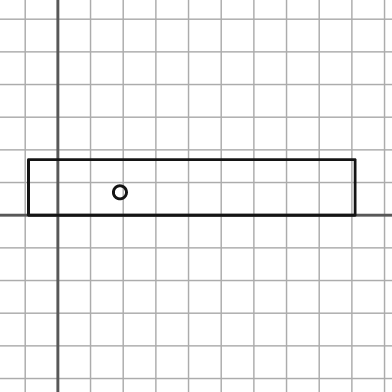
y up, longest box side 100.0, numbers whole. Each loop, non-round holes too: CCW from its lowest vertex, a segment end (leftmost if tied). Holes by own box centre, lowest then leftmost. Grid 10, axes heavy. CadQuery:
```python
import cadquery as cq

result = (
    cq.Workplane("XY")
    .moveTo(-9.0, 0.0)
    .lineTo(91.0, 0.0)
    .lineTo(91.0, 17.0)
    .lineTo(-9.0, 17.0)
    .close()
    .moveTo(19.0, 7.0)
    .circle(2.0)
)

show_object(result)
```